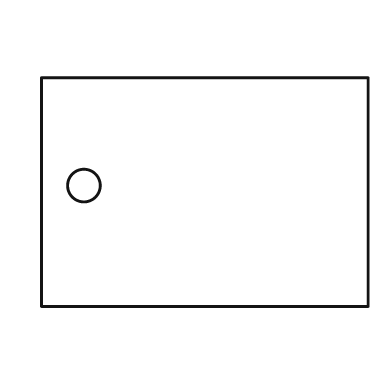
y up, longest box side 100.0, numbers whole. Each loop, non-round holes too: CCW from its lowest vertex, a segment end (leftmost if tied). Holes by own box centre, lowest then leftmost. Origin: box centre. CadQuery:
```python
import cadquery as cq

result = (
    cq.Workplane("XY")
    .moveTo(-50.0, -35.0)
    .lineTo(50.0, -35.0)
    .lineTo(50.0, 35.0)
    .lineTo(-50.0, 35.0)
    .close()
    .moveTo(-37.0, 2.0)
    .circle(5.0)
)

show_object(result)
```